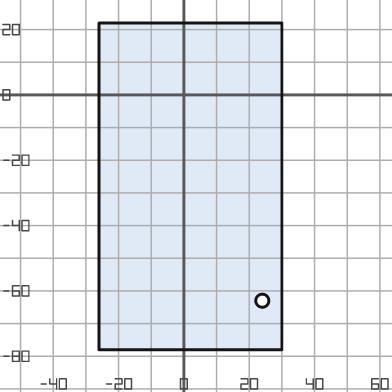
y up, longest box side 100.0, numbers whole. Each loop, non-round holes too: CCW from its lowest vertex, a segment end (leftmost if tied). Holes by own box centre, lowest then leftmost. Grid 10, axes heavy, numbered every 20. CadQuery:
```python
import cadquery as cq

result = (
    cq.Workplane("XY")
    .moveTo(-26.0, -78.0)
    .lineTo(30.0, -78.0)
    .lineTo(30.0, 22.0)
    .lineTo(-26.0, 22.0)
    .close()
    .moveTo(24.0, -63.0)
    .circle(2.0)
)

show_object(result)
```